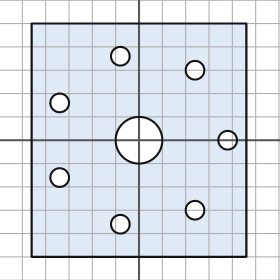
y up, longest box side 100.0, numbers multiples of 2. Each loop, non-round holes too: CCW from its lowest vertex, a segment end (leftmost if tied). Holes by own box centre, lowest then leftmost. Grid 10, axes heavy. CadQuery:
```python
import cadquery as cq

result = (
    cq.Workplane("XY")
    .moveTo(-46.0, -50.0)
    .lineTo(46.0, -50.0)
    .lineTo(46.0, 50.0)
    .lineTo(-46.0, 50.0)
    .close()
    .moveTo(-8.0, -36.0)
    .circle(4.0)
    .moveTo(24.0, -30.0)
    .circle(4.0)
    .moveTo(-34.0, -16.0)
    .circle(4.0)
    .moveTo(0.0, 0.0)
    .circle(10.0)
    .moveTo(38.0, 0.0)
    .circle(4.0)
    .moveTo(-34.0, 16.0)
    .circle(4.0)
    .moveTo(24.0, 30.0)
    .circle(4.0)
    .moveTo(-8.0, 36.0)
    .circle(4.0)
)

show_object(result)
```